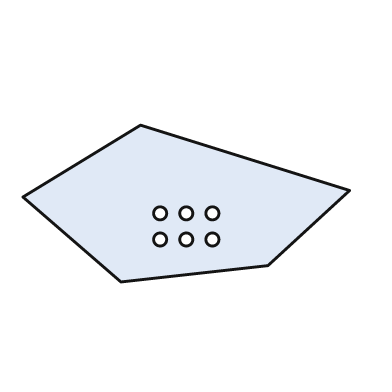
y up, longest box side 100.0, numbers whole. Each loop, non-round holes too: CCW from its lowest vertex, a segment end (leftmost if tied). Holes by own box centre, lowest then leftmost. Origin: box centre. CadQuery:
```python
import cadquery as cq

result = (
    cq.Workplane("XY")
    .moveTo(-20.0, -24.0)
    .lineTo(25.0, -19.0)
    .lineTo(50.0, 4.0)
    .lineTo(-14.0, 24.0)
    .lineTo(-50.0, 2.0)
    .close()
    .moveTo(-8.0, -11.0)
    .circle(2.0)
    .moveTo(0.0, -11.0)
    .circle(2.0)
    .moveTo(8.0, -11.0)
    .circle(2.0)
    .moveTo(-8.0, -3.0)
    .circle(2.0)
    .moveTo(0.0, -3.0)
    .circle(2.0)
    .moveTo(8.0, -3.0)
    .circle(2.0)
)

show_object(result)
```